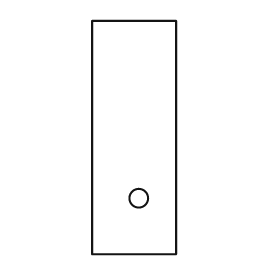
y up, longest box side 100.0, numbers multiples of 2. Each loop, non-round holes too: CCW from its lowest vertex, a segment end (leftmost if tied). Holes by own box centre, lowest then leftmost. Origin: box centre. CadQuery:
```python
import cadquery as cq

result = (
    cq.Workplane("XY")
    .moveTo(-18.0, -50.0)
    .lineTo(18.0, -50.0)
    .lineTo(18.0, 50.0)
    .lineTo(-18.0, 50.0)
    .close()
    .moveTo(2.0, -26.0)
    .circle(4.0)
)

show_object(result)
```